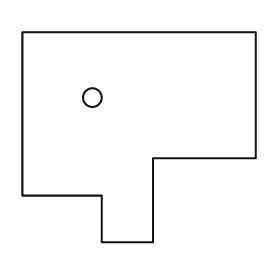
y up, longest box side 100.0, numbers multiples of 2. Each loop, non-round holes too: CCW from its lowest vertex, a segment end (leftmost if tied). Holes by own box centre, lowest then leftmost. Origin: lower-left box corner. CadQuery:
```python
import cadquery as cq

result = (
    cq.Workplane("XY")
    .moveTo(34.0, 0.0)
    .lineTo(56.0, 0.0)
    .lineTo(56.0, 36.0)
    .lineTo(100.0, 36.0)
    .lineTo(100.0, 90.0)
    .lineTo(0.0, 90.0)
    .lineTo(0.0, 20.0)
    .lineTo(34.0, 20.0)
    .close()
    .moveTo(30.0, 62.0)
    .circle(4.0)
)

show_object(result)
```